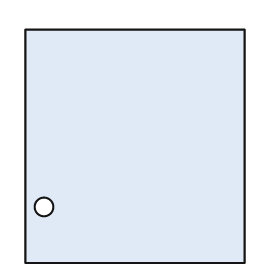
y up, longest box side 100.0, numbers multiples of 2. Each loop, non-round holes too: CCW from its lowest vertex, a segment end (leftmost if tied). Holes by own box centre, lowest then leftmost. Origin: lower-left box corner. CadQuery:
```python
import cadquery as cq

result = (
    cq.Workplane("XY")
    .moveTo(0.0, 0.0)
    .lineTo(94.0, 0.0)
    .lineTo(94.0, 100.0)
    .lineTo(0.0, 100.0)
    .close()
    .moveTo(8.0, 24.0)
    .circle(4.0)
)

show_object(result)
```